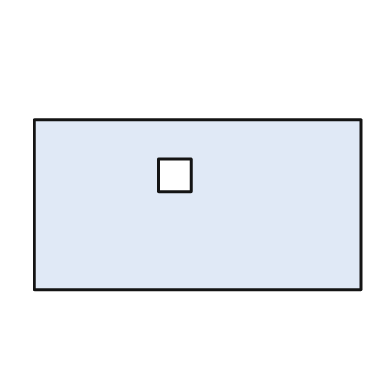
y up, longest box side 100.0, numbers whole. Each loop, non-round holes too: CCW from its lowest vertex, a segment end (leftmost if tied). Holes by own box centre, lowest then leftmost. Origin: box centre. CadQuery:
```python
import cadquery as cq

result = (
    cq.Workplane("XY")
    .moveTo(-50.0, -26.0)
    .lineTo(50.0, -26.0)
    .lineTo(50.0, 26.0)
    .lineTo(-50.0, 26.0)
    .close()
    .moveTo(-12.0, 4.0)
    .lineTo(-2.0, 4.0)
    .lineTo(-2.0, 14.0)
    .lineTo(-12.0, 14.0)
    .close()
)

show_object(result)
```